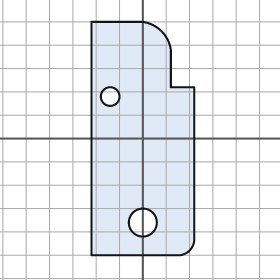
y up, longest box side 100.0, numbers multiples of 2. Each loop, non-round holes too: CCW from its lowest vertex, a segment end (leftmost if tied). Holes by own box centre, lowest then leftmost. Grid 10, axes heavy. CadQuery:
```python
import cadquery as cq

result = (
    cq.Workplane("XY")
    .moveTo(-22.0, -50.0)
    .lineTo(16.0, -50.0)
    .threePointArc((20.0, -48.0), (22.0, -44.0))
    .lineTo(22.0, 22.0)
    .lineTo(12.0, 22.0)
    .lineTo(12.0, 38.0)
    .threePointArc((8.0, 46.0), (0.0, 50.0))
    .lineTo(-22.0, 50.0)
    .close()
    .moveTo(0.0, -36.0)
    .circle(6.0)
    .moveTo(-14.0, 18.0)
    .circle(4.0)
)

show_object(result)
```